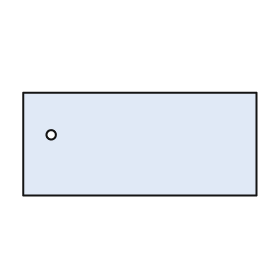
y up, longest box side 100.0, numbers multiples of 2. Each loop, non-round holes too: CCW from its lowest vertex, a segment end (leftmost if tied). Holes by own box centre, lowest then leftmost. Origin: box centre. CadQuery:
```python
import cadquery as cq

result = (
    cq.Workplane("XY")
    .moveTo(-50.0, -22.0)
    .lineTo(50.0, -22.0)
    .lineTo(50.0, 22.0)
    .lineTo(-50.0, 22.0)
    .close()
    .moveTo(-38.0, 4.0)
    .circle(2.0)
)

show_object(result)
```